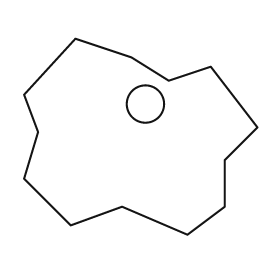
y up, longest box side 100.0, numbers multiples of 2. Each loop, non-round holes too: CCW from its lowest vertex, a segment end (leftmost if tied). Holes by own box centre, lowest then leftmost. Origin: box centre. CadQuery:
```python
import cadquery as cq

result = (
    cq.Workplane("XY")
    .moveTo(20.0, -42.0)
    .lineTo(36.0, -30.0)
    .lineTo(36.0, -10.0)
    .lineTo(50.0, 4.0)
    .lineTo(30.0, 30.0)
    .lineTo(12.0, 24.0)
    .lineTo(-4.0, 34.0)
    .lineTo(-28.0, 42.0)
    .lineTo(-50.0, 18.0)
    .lineTo(-44.0, 2.0)
    .lineTo(-50.0, -18.0)
    .lineTo(-30.0, -38.0)
    .lineTo(-8.0, -30.0)
    .close()
    .moveTo(2.0, 14.0)
    .circle(8.0)
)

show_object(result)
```